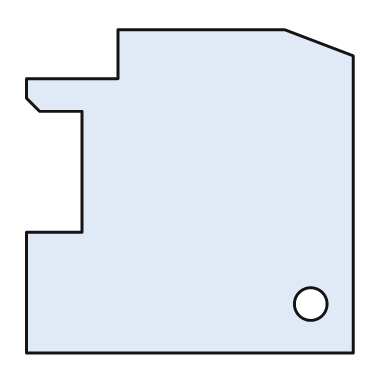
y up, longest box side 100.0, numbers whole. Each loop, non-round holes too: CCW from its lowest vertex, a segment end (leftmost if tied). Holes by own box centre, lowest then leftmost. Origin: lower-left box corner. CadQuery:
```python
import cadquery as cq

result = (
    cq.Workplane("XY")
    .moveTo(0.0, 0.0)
    .lineTo(100.0, 0.0)
    .lineTo(100.0, 91.0)
    .lineTo(79.0, 99.0)
    .lineTo(28.0, 99.0)
    .lineTo(28.0, 84.0)
    .lineTo(0.0, 84.0)
    .lineTo(0.0, 78.0)
    .lineTo(4.0, 74.0)
    .lineTo(17.0, 74.0)
    .lineTo(17.0, 37.0)
    .lineTo(0.0, 37.0)
    .close()
    .moveTo(87.0, 15.0)
    .circle(5.0)
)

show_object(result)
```